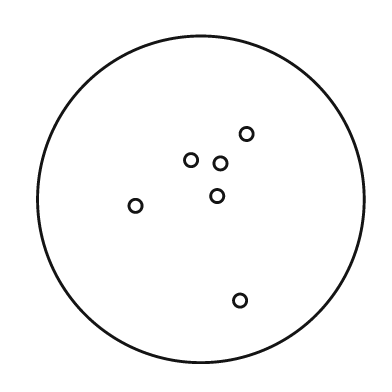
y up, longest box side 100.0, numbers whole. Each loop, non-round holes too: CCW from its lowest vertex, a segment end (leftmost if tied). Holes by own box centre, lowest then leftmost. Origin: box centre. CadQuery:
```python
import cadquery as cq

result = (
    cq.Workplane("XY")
    .moveTo(0.0, 0.0)
    .circle(50.0)
    .moveTo(12.0, -31.0)
    .circle(2.0)
    .moveTo(-20.0, -2.0)
    .circle(2.0)
    .moveTo(5.0, 1.0)
    .circle(2.0)
    .moveTo(6.0, 11.0)
    .circle(2.0)
    .moveTo(-3.0, 12.0)
    .circle(2.0)
    .moveTo(14.0, 20.0)
    .circle(2.0)
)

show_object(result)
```